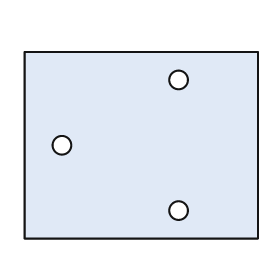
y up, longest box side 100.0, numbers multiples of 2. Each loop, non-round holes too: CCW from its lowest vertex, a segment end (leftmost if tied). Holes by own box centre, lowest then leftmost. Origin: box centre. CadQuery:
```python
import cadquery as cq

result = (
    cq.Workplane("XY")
    .moveTo(-50.0, -40.0)
    .lineTo(50.0, -40.0)
    .lineTo(50.0, 40.0)
    .lineTo(-50.0, 40.0)
    .close()
    .moveTo(16.0, -28.0)
    .circle(4.0)
    .moveTo(-34.0, 0.0)
    .circle(4.0)
    .moveTo(16.0, 28.0)
    .circle(4.0)
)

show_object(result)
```